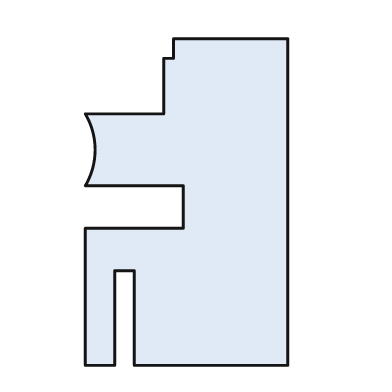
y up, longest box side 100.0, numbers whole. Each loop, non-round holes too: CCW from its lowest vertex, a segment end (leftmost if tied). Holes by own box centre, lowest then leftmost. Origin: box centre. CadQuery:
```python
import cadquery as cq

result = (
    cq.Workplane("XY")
    .moveTo(-31.0, -50.0)
    .lineTo(-22.0, -50.0)
    .lineTo(-22.0, -21.0)
    .lineTo(-16.0, -21.0)
    .lineTo(-16.0, -50.0)
    .lineTo(31.0, -50.0)
    .lineTo(31.0, 50.0)
    .lineTo(-4.0, 50.0)
    .lineTo(-4.0, 44.0)
    .lineTo(-7.0, 44.0)
    .lineTo(-7.0, 27.0)
    .lineTo(-31.0, 27.0)
    .threePointArc((-28.0, 16.0), (-31.0, 5.0))
    .lineTo(-1.0, 5.0)
    .lineTo(-1.0, -8.0)
    .lineTo(-31.0, -8.0)
    .close()
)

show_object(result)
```